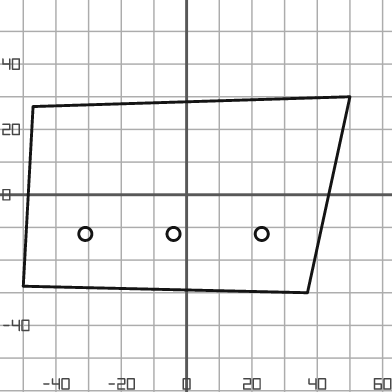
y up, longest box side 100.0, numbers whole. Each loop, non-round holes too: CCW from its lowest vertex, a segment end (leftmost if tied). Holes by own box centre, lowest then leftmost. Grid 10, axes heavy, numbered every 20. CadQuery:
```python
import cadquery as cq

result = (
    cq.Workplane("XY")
    .moveTo(37.0, -30.0)
    .lineTo(50.0, 30.0)
    .lineTo(-47.0, 27.0)
    .lineTo(-50.0, -28.0)
    .close()
    .moveTo(-31.0, -12.0)
    .circle(2.0)
    .moveTo(-4.0, -12.0)
    .circle(2.0)
    .moveTo(23.0, -12.0)
    .circle(2.0)
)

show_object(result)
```